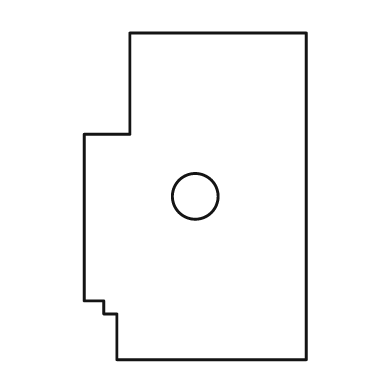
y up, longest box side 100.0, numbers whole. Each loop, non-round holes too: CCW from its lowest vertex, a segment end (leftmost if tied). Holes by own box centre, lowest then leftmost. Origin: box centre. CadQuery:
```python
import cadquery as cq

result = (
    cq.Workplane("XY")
    .moveTo(-24.0, -50.0)
    .lineTo(34.0, -50.0)
    .lineTo(34.0, 50.0)
    .lineTo(-20.0, 50.0)
    .lineTo(-20.0, 19.0)
    .lineTo(-34.0, 19.0)
    .lineTo(-34.0, -32.0)
    .lineTo(-28.0, -32.0)
    .lineTo(-28.0, -36.0)
    .lineTo(-24.0, -36.0)
    .close()
    .moveTo(0.0, 0.0)
    .circle(7.0)
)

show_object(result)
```